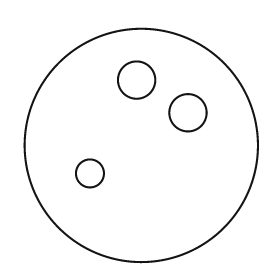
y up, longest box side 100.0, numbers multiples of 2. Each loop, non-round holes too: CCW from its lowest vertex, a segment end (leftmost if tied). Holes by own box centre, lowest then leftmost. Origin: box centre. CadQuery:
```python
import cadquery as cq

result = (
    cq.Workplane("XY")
    .moveTo(0.0, 0.0)
    .circle(50.0)
    .moveTo(-22.0, -12.0)
    .circle(6.0)
    .moveTo(20.0, 14.0)
    .circle(8.0)
    .moveTo(-2.0, 28.0)
    .circle(8.0)
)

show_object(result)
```